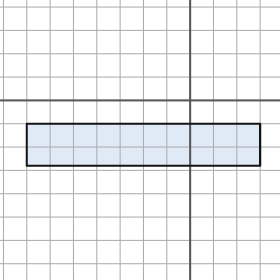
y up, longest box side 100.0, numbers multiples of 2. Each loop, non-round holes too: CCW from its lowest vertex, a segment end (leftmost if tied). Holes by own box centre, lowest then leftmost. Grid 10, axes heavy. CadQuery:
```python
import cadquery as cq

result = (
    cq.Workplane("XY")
    .moveTo(-70.0, -28.0)
    .lineTo(30.0, -28.0)
    .lineTo(30.0, -10.0)
    .lineTo(-70.0, -10.0)
    .close()
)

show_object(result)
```